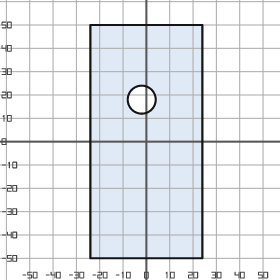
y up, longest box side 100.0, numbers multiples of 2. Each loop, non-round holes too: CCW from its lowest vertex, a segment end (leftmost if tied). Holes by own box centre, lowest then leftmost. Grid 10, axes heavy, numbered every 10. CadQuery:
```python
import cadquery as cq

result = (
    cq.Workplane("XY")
    .moveTo(-24.0, -50.0)
    .lineTo(24.0, -50.0)
    .lineTo(24.0, 50.0)
    .lineTo(-24.0, 50.0)
    .close()
    .moveTo(-2.0, 18.0)
    .circle(6.0)
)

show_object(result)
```